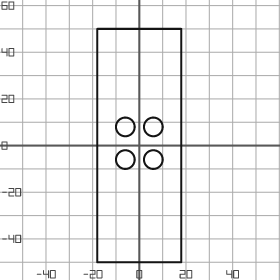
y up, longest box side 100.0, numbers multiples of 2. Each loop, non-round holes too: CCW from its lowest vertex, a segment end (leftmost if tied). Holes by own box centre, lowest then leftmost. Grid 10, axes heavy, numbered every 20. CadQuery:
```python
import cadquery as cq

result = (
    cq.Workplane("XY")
    .moveTo(-18.0, -50.0)
    .lineTo(18.0, -50.0)
    .lineTo(18.0, 50.0)
    .lineTo(-18.0, 50.0)
    .close()
    .moveTo(-6.0, -6.0)
    .circle(4.0)
    .moveTo(6.0, -6.0)
    .circle(4.0)
    .moveTo(-6.0, 8.0)
    .circle(4.0)
    .moveTo(6.0, 8.0)
    .circle(4.0)
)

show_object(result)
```